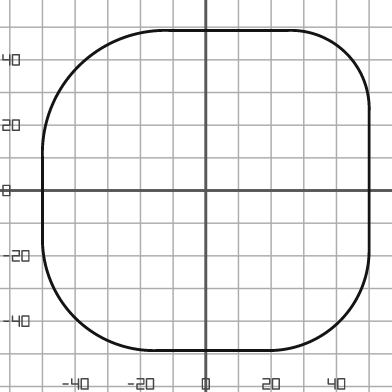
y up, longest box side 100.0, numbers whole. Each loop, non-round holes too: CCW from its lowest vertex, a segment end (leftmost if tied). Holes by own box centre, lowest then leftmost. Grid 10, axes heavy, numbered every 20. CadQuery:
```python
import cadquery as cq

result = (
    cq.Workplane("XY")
    .moveTo(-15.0, -49.0)
    .lineTo(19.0, -49.0)
    .threePointArc((41.0, -40.0), (50.0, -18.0))
    .lineTo(50.0, 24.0)
    .threePointArc((43.0, 42.0), (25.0, 49.0))
    .lineTo(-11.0, 49.0)
    .threePointArc((-39.0, 38.0), (-50.0, 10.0))
    .lineTo(-50.0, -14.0)
    .threePointArc((-40.0, -39.0), (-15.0, -49.0))
    .close()
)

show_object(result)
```